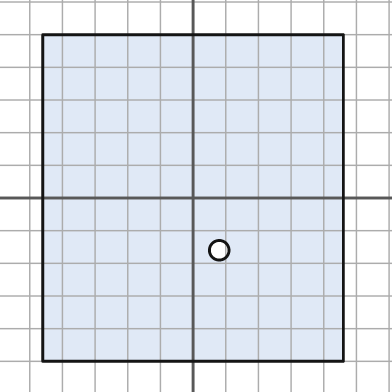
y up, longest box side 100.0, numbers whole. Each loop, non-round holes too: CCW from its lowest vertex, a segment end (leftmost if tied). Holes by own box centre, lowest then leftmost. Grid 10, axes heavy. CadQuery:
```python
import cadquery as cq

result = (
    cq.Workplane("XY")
    .moveTo(-46.0, -50.0)
    .lineTo(46.0, -50.0)
    .lineTo(46.0, 50.0)
    .lineTo(-46.0, 50.0)
    .close()
    .moveTo(8.0, -16.0)
    .circle(3.0)
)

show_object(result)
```